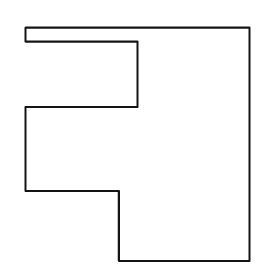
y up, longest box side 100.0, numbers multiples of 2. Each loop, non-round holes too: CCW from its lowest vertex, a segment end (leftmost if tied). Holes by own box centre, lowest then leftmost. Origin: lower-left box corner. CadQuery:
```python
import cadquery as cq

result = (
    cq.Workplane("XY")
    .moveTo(40.0, 0.0)
    .lineTo(96.0, 0.0)
    .lineTo(96.0, 100.0)
    .lineTo(0.0, 100.0)
    .lineTo(0.0, 94.0)
    .lineTo(48.0, 94.0)
    .lineTo(48.0, 66.0)
    .lineTo(0.0, 66.0)
    .lineTo(0.0, 30.0)
    .lineTo(40.0, 30.0)
    .close()
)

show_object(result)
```